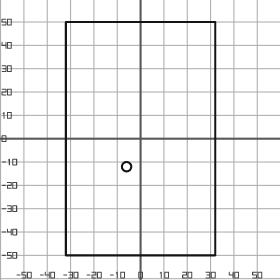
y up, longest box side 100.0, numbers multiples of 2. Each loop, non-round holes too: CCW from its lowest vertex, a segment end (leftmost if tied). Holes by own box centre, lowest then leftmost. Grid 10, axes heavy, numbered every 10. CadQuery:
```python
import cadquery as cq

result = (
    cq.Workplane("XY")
    .moveTo(-32.0, -50.0)
    .lineTo(32.0, -50.0)
    .lineTo(32.0, 50.0)
    .lineTo(-32.0, 50.0)
    .close()
    .moveTo(-6.0, -12.0)
    .circle(2.0)
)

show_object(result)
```